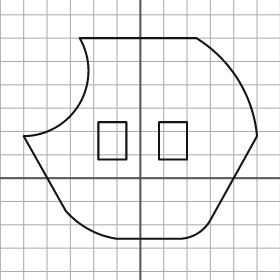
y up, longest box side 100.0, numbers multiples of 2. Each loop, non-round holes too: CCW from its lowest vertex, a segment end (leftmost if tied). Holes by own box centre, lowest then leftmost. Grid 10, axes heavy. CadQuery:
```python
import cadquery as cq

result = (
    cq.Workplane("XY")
    .moveTo(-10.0, -26.0)
    .lineTo(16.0, -26.0)
    .threePointArc((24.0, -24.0), (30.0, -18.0))
    .lineTo(50.0, 18.0)
    .threePointArc((42.0, 42.0), (24.0, 60.0))
    .lineTo(-26.0, 60.0)
    .threePointArc((-26.0, 32.0), (-50.0, 18.0))
    .lineTo(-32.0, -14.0)
    .threePointArc((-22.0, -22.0), (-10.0, -26.0))
    .close()
    .moveTo(-18.0, 8.0)
    .lineTo(-6.0, 8.0)
    .lineTo(-6.0, 24.0)
    .lineTo(-18.0, 24.0)
    .close()
    .moveTo(8.0, 8.0)
    .lineTo(20.0, 8.0)
    .lineTo(20.0, 24.0)
    .lineTo(8.0, 24.0)
    .close()
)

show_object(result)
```